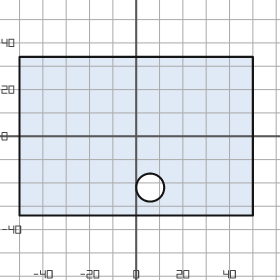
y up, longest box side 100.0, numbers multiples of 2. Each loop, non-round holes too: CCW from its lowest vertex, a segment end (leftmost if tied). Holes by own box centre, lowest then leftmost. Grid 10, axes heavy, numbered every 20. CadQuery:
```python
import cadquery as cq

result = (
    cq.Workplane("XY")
    .moveTo(-50.0, -34.0)
    .lineTo(50.0, -34.0)
    .lineTo(50.0, 34.0)
    .lineTo(-50.0, 34.0)
    .close()
    .moveTo(6.0, -22.0)
    .circle(6.0)
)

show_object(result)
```